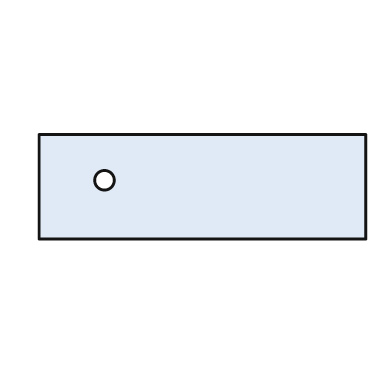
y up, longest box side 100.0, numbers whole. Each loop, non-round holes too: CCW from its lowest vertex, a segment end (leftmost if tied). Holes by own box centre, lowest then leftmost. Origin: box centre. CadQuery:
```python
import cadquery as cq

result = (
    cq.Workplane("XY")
    .moveTo(-50.0, -16.0)
    .lineTo(50.0, -16.0)
    .lineTo(50.0, 16.0)
    .lineTo(-50.0, 16.0)
    .close()
    .moveTo(-30.0, 2.0)
    .circle(3.0)
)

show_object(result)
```